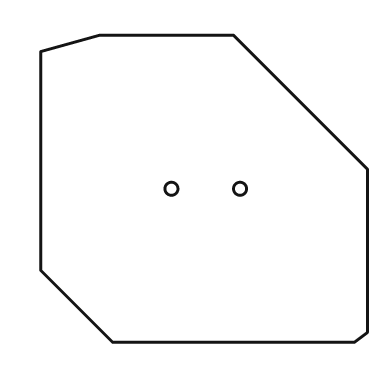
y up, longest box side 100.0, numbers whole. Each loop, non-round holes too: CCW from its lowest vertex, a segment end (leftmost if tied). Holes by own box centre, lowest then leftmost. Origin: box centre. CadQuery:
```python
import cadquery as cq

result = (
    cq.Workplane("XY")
    .moveTo(-28.0, -47.0)
    .lineTo(46.0, -47.0)
    .lineTo(50.0, -44.0)
    .lineTo(50.0, 6.0)
    .lineTo(9.0, 47.0)
    .lineTo(-32.0, 47.0)
    .lineTo(-50.0, 42.0)
    .lineTo(-50.0, -25.0)
    .close()
    .moveTo(-10.0, 0.0)
    .circle(2.0)
    .moveTo(11.0, 0.0)
    .circle(2.0)
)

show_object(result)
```